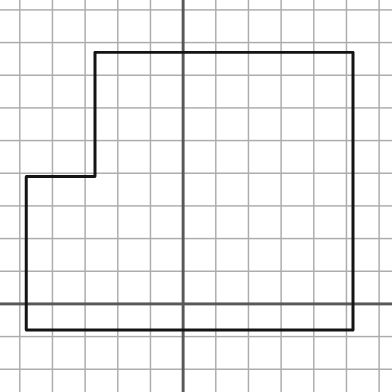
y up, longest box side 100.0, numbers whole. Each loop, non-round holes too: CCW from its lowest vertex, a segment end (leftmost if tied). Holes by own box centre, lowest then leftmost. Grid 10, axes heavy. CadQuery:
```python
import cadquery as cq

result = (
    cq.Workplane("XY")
    .moveTo(-48.0, -8.0)
    .lineTo(52.0, -8.0)
    .lineTo(52.0, 77.0)
    .lineTo(-27.0, 77.0)
    .lineTo(-27.0, 39.0)
    .lineTo(-48.0, 39.0)
    .close()
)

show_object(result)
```